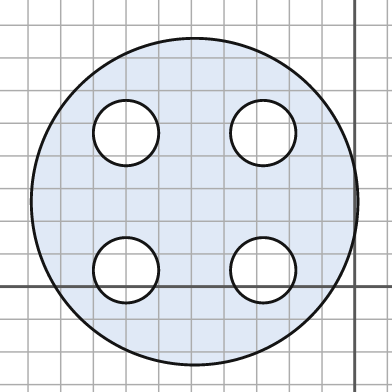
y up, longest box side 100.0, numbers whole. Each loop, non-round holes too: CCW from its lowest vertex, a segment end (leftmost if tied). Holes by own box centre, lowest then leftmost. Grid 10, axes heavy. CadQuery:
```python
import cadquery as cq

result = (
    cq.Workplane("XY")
    .moveTo(-49.0, 26.0)
    .circle(50.0)
    .moveTo(-70.0, 5.0)
    .circle(10.0)
    .moveTo(-28.0, 5.0)
    .circle(10.0)
    .moveTo(-70.0, 47.0)
    .circle(10.0)
    .moveTo(-28.0, 47.0)
    .circle(10.0)
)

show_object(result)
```